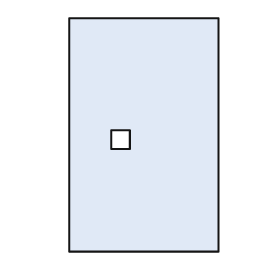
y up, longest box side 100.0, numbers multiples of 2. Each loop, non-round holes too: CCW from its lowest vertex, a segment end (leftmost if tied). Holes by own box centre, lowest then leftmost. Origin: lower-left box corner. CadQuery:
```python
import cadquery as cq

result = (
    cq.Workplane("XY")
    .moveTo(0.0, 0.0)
    .lineTo(64.0, 0.0)
    .lineTo(64.0, 100.0)
    .lineTo(0.0, 100.0)
    .close()
    .moveTo(18.0, 44.0)
    .lineTo(26.0, 44.0)
    .lineTo(26.0, 52.0)
    .lineTo(18.0, 52.0)
    .close()
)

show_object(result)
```